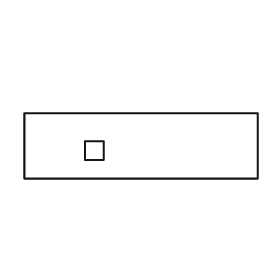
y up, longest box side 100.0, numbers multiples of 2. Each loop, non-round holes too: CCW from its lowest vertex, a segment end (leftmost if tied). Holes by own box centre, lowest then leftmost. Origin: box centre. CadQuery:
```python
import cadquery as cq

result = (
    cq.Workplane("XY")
    .moveTo(-50.0, -14.0)
    .lineTo(50.0, -14.0)
    .lineTo(50.0, 14.0)
    .lineTo(-50.0, 14.0)
    .close()
    .moveTo(-24.0, -6.0)
    .lineTo(-16.0, -6.0)
    .lineTo(-16.0, 2.0)
    .lineTo(-24.0, 2.0)
    .close()
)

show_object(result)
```